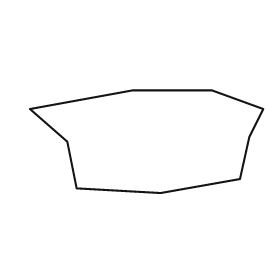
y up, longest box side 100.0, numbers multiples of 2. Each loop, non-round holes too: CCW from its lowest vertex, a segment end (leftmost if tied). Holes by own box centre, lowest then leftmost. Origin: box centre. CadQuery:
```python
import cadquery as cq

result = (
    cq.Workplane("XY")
    .moveTo(6.0, -22.0)
    .lineTo(40.0, -16.0)
    .lineTo(44.0, 2.0)
    .lineTo(50.0, 14.0)
    .lineTo(28.0, 22.0)
    .lineTo(-6.0, 22.0)
    .lineTo(-50.0, 14.0)
    .lineTo(-34.0, 0.0)
    .lineTo(-30.0, -20.0)
    .close()
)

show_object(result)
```